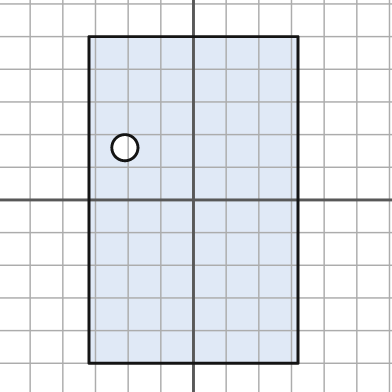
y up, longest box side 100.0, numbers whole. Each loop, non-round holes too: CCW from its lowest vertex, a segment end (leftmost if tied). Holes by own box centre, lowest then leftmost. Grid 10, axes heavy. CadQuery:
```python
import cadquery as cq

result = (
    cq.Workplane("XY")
    .moveTo(-32.0, -50.0)
    .lineTo(32.0, -50.0)
    .lineTo(32.0, 50.0)
    .lineTo(-32.0, 50.0)
    .close()
    .moveTo(-21.0, 16.0)
    .circle(4.0)
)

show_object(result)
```